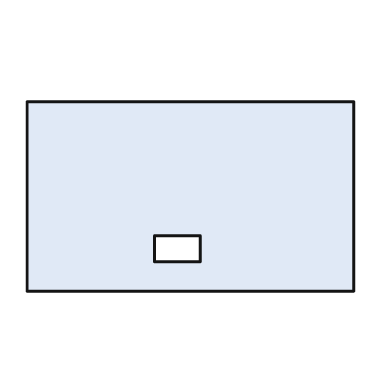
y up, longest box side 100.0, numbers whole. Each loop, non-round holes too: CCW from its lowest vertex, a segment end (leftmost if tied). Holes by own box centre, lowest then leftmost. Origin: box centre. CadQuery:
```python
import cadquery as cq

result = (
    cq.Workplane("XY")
    .moveTo(-50.0, -29.0)
    .lineTo(50.0, -29.0)
    .lineTo(50.0, 29.0)
    .lineTo(-50.0, 29.0)
    .close()
    .moveTo(-11.0, -20.0)
    .lineTo(3.0, -20.0)
    .lineTo(3.0, -12.0)
    .lineTo(-11.0, -12.0)
    .close()
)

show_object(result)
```